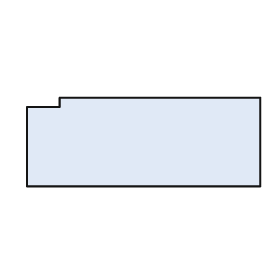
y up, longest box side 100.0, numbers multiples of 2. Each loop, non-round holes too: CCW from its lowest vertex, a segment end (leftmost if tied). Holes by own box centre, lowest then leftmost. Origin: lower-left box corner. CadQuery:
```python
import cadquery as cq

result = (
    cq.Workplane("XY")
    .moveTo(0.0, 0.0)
    .lineTo(100.0, 0.0)
    .lineTo(100.0, 38.0)
    .lineTo(14.0, 38.0)
    .lineTo(14.0, 34.0)
    .lineTo(0.0, 34.0)
    .close()
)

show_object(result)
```